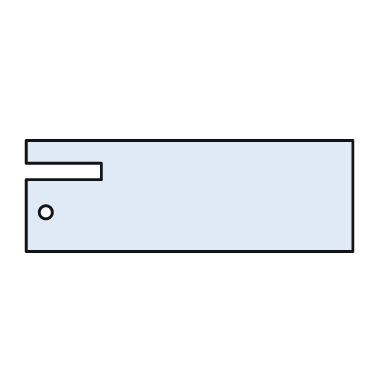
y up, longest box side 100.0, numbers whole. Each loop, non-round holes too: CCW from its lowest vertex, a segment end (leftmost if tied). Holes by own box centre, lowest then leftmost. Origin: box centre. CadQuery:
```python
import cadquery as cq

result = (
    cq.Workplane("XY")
    .moveTo(-50.0, -17.0)
    .lineTo(50.0, -17.0)
    .lineTo(50.0, 17.0)
    .lineTo(-50.0, 17.0)
    .lineTo(-50.0, 10.0)
    .lineTo(-27.0, 10.0)
    .lineTo(-27.0, 5.0)
    .lineTo(-50.0, 5.0)
    .close()
    .moveTo(-44.0, -5.0)
    .circle(2.0)
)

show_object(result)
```